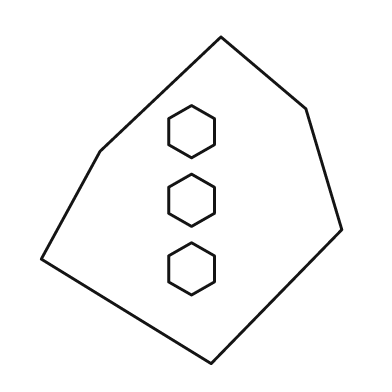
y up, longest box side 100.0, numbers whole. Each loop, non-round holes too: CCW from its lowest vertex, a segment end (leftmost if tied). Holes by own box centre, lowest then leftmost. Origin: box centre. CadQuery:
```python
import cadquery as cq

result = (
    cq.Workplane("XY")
    .moveTo(6.0, -50.0)
    .lineTo(46.0, -9.0)
    .lineTo(35.0, 28.0)
    .lineTo(9.0, 50.0)
    .lineTo(-28.0, 15.0)
    .lineTo(-46.0, -18.0)
    .close()
    .moveTo(0.0, -29.0)
    .lineTo(7.0, -25.0)
    .lineTo(7.0, -17.0)
    .lineTo(0.0, -13.0)
    .lineTo(-7.0, -17.0)
    .lineTo(-7.0, -25.0)
    .close()
    .moveTo(0.0, -8.0)
    .lineTo(7.0, -4.0)
    .lineTo(7.0, 4.0)
    .lineTo(0.0, 8.0)
    .lineTo(-7.0, 4.0)
    .lineTo(-7.0, -4.0)
    .close()
    .moveTo(0.0, 13.0)
    .lineTo(7.0, 17.0)
    .lineTo(7.0, 25.0)
    .lineTo(0.0, 29.0)
    .lineTo(-7.0, 25.0)
    .lineTo(-7.0, 17.0)
    .close()
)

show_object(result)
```